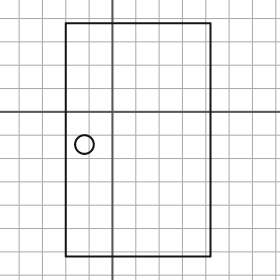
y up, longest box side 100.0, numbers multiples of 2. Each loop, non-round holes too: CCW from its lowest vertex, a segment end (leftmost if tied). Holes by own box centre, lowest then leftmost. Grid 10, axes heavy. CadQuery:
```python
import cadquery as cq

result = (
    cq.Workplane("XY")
    .moveTo(-20.0, -62.0)
    .lineTo(42.0, -62.0)
    .lineTo(42.0, 38.0)
    .lineTo(-20.0, 38.0)
    .close()
    .moveTo(-12.0, -14.0)
    .circle(4.0)
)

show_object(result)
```